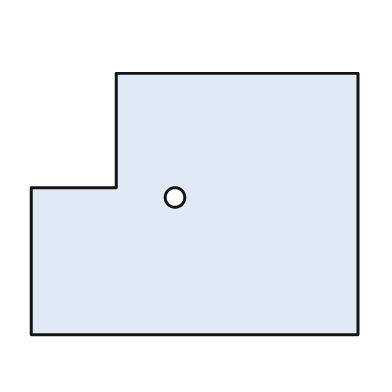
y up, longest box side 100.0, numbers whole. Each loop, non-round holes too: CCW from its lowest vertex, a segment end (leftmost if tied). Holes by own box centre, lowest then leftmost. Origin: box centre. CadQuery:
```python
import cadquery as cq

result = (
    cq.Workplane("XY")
    .moveTo(-50.0, -40.0)
    .lineTo(50.0, -40.0)
    .lineTo(50.0, 40.0)
    .lineTo(-24.0, 40.0)
    .lineTo(-24.0, 5.0)
    .lineTo(-50.0, 5.0)
    .close()
    .moveTo(-6.0, 2.0)
    .circle(3.0)
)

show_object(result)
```